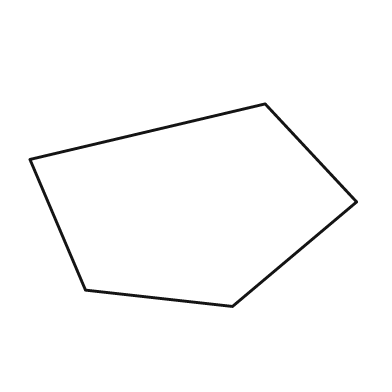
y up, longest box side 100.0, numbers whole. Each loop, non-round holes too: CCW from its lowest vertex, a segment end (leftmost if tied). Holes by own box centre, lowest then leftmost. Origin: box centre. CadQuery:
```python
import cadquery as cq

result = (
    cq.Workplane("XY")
    .moveTo(12.0, -31.0)
    .lineTo(50.0, 1.0)
    .lineTo(22.0, 31.0)
    .lineTo(-50.0, 14.0)
    .lineTo(-33.0, -26.0)
    .close()
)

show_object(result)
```